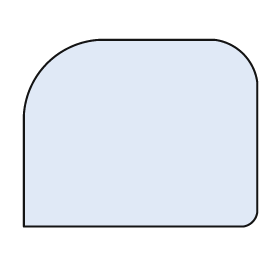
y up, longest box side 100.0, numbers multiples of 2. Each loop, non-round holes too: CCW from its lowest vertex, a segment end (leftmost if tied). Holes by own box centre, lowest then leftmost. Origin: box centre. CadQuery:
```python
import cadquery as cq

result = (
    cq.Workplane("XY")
    .moveTo(-50.0, -40.0)
    .lineTo(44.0, -40.0)
    .threePointArc((48.0, -38.0), (50.0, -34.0))
    .lineTo(50.0, 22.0)
    .threePointArc((44.0, 34.0), (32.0, 40.0))
    .lineTo(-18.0, 40.0)
    .threePointArc((-40.0, 30.0), (-50.0, 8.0))
    .close()
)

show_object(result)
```